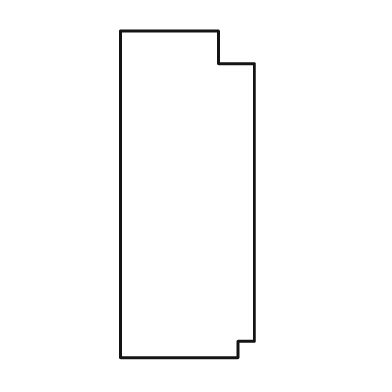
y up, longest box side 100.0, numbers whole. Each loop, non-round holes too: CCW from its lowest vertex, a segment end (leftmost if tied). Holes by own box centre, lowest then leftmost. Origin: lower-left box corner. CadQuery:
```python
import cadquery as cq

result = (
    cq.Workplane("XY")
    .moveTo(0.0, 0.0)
    .lineTo(36.0, 0.0)
    .lineTo(36.0, 5.0)
    .lineTo(41.0, 5.0)
    .lineTo(41.0, 90.0)
    .lineTo(30.0, 90.0)
    .lineTo(30.0, 100.0)
    .lineTo(0.0, 100.0)
    .close()
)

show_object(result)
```